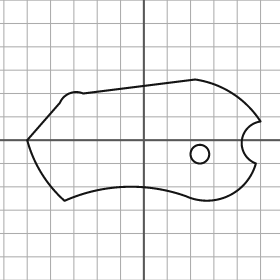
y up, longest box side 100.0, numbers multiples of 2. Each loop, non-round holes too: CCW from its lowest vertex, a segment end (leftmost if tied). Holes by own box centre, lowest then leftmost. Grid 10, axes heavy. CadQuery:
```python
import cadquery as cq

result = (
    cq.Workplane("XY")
    .moveTo(-34.0, -26.0)
    .threePointArc((-8.0, -20.0), (18.0, -24.0))
    .threePointArc((36.0, -24.0), (48.0, -10.0))
    .threePointArc((42.0, 0.0), (50.0, 8.0))
    .threePointArc((38.0, 20.0), (22.0, 26.0))
    .lineTo(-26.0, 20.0)
    .threePointArc((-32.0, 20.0), (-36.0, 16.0))
    .lineTo(-50.0, 0.0)
    .threePointArc((-44.0, -14.0), (-34.0, -26.0))
    .close()
    .moveTo(24.0, -6.0)
    .circle(4.0)
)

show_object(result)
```